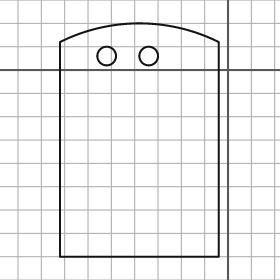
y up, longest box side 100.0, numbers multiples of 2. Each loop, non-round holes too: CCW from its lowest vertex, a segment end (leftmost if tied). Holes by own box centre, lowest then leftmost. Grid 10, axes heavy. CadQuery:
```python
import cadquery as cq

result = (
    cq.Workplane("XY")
    .moveTo(-72.0, -80.0)
    .lineTo(-4.0, -80.0)
    .lineTo(-4.0, 12.0)
    .threePointArc((-38.0, 20.0), (-72.0, 12.0))
    .close()
    .moveTo(-52.0, 6.0)
    .circle(4.0)
    .moveTo(-34.0, 6.0)
    .circle(4.0)
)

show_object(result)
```